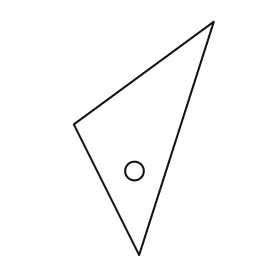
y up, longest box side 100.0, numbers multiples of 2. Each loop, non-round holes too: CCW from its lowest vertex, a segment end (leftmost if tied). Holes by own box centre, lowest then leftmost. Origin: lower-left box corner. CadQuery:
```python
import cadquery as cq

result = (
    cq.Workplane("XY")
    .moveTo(28.0, 0.0)
    .lineTo(60.0, 100.0)
    .lineTo(0.0, 56.0)
    .close()
    .moveTo(26.0, 36.0)
    .circle(4.0)
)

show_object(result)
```